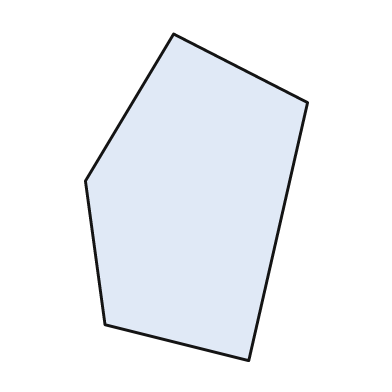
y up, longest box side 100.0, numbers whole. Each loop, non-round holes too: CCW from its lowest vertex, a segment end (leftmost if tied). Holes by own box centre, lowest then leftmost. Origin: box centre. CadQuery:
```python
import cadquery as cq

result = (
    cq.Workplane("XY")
    .moveTo(16.0, -50.0)
    .lineTo(34.0, 29.0)
    .lineTo(-7.0, 50.0)
    .lineTo(-34.0, 5.0)
    .lineTo(-28.0, -39.0)
    .close()
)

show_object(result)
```